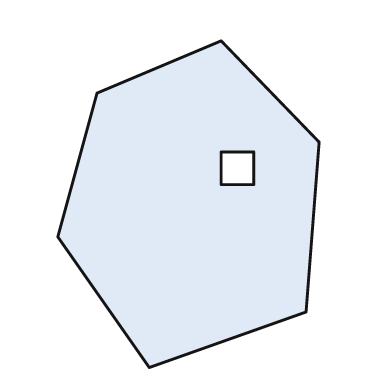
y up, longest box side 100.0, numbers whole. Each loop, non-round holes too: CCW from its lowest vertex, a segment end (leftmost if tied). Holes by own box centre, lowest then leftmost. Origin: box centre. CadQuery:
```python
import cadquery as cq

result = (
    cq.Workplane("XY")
    .moveTo(-12.0, -50.0)
    .lineTo(36.0, -33.0)
    .lineTo(40.0, 19.0)
    .lineTo(10.0, 50.0)
    .lineTo(-28.0, 34.0)
    .lineTo(-40.0, -10.0)
    .close()
    .moveTo(10.0, 6.0)
    .lineTo(20.0, 6.0)
    .lineTo(20.0, 16.0)
    .lineTo(10.0, 16.0)
    .close()
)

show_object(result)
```